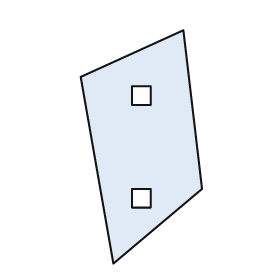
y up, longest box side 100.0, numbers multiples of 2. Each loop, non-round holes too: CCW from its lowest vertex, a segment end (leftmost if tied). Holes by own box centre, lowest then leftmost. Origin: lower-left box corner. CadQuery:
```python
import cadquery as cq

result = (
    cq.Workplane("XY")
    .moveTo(14.0, 0.0)
    .lineTo(52.0, 32.0)
    .lineTo(44.0, 100.0)
    .lineTo(0.0, 80.0)
    .close()
    .moveTo(22.0, 24.0)
    .lineTo(30.0, 24.0)
    .lineTo(30.0, 32.0)
    .lineTo(22.0, 32.0)
    .close()
    .moveTo(22.0, 68.0)
    .lineTo(30.0, 68.0)
    .lineTo(30.0, 76.0)
    .lineTo(22.0, 76.0)
    .close()
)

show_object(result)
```